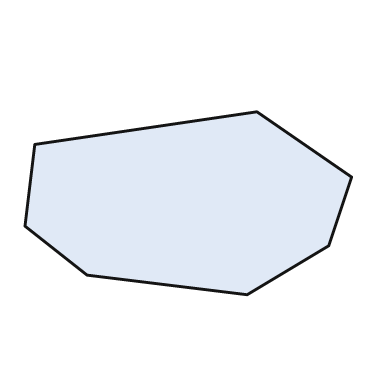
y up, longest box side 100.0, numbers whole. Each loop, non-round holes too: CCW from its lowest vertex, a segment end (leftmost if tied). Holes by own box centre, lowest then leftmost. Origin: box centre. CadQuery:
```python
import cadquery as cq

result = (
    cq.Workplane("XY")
    .moveTo(18.0, -28.0)
    .lineTo(43.0, -13.0)
    .lineTo(50.0, 8.0)
    .lineTo(21.0, 28.0)
    .lineTo(-47.0, 18.0)
    .lineTo(-50.0, -7.0)
    .lineTo(-31.0, -22.0)
    .close()
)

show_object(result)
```